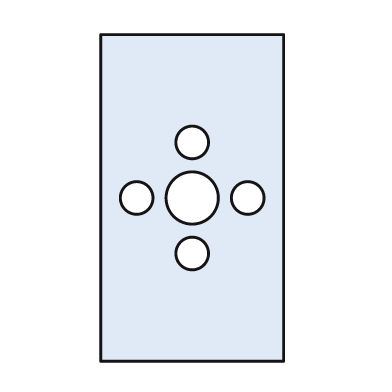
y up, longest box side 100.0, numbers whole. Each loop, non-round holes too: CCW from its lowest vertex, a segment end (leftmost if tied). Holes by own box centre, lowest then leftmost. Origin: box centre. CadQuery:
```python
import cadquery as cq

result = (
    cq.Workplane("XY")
    .moveTo(-28.0, -50.0)
    .lineTo(28.0, -50.0)
    .lineTo(28.0, 50.0)
    .lineTo(-28.0, 50.0)
    .close()
    .moveTo(0.0, -17.0)
    .circle(5.0)
    .moveTo(-17.0, 0.0)
    .circle(5.0)
    .moveTo(0.0, 0.0)
    .circle(8.0)
    .moveTo(17.0, 0.0)
    .circle(5.0)
    .moveTo(0.0, 17.0)
    .circle(5.0)
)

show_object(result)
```